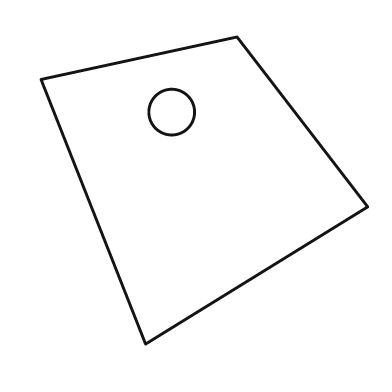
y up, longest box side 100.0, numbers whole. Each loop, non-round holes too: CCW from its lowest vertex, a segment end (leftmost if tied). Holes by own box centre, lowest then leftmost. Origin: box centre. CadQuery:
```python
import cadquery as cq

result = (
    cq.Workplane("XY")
    .moveTo(-18.0, -47.0)
    .lineTo(50.0, -5.0)
    .lineTo(10.0, 47.0)
    .lineTo(-50.0, 34.0)
    .close()
    .moveTo(-10.0, 24.0)
    .circle(7.0)
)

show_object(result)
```